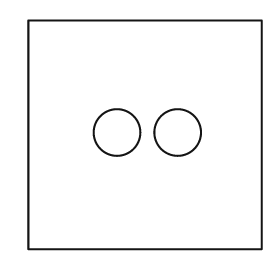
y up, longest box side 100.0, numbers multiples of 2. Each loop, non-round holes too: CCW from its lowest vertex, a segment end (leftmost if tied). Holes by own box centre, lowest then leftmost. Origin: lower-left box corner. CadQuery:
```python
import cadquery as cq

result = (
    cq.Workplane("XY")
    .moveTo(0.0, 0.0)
    .lineTo(100.0, 0.0)
    .lineTo(100.0, 98.0)
    .lineTo(0.0, 98.0)
    .close()
    .moveTo(38.0, 50.0)
    .circle(10.0)
    .moveTo(64.0, 50.0)
    .circle(10.0)
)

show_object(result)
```